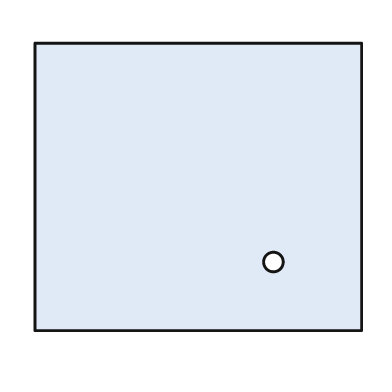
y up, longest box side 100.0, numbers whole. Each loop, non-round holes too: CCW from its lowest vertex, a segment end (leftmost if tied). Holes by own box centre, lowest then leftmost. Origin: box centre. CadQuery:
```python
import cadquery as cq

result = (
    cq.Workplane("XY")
    .moveTo(-50.0, -44.0)
    .lineTo(50.0, -44.0)
    .lineTo(50.0, 44.0)
    .lineTo(-50.0, 44.0)
    .close()
    .moveTo(23.0, -23.0)
    .circle(3.0)
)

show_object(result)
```